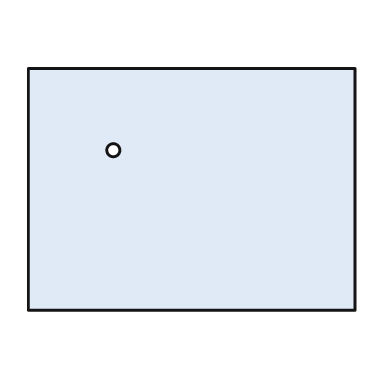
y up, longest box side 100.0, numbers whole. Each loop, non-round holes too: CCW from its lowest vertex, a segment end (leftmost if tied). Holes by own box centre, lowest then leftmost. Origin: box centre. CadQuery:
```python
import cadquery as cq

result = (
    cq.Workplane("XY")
    .moveTo(-50.0, -37.0)
    .lineTo(50.0, -37.0)
    .lineTo(50.0, 37.0)
    .lineTo(-50.0, 37.0)
    .close()
    .moveTo(-24.0, 12.0)
    .circle(2.0)
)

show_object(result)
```